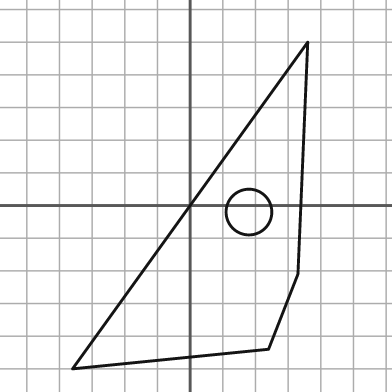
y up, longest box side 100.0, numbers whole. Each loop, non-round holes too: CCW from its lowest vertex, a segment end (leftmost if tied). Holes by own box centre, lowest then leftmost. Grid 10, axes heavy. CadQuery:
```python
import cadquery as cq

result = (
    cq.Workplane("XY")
    .moveTo(-36.0, -50.0)
    .lineTo(24.0, -44.0)
    .lineTo(33.0, -21.0)
    .lineTo(36.0, 50.0)
    .close()
    .moveTo(18.0, -2.0)
    .circle(7.0)
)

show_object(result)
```